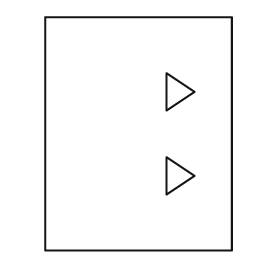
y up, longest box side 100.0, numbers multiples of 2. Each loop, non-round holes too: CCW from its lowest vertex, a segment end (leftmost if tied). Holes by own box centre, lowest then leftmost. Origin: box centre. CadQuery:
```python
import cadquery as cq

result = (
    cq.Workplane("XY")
    .moveTo(-40.0, -50.0)
    .lineTo(40.0, -50.0)
    .lineTo(40.0, 50.0)
    .lineTo(-40.0, 50.0)
    .close()
    .moveTo(12.0, -26.0)
    .lineTo(24.0, -18.0)
    .lineTo(12.0, -10.0)
    .close()
    .moveTo(12.0, 10.0)
    .lineTo(24.0, 18.0)
    .lineTo(12.0, 26.0)
    .close()
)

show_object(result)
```